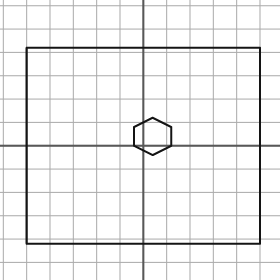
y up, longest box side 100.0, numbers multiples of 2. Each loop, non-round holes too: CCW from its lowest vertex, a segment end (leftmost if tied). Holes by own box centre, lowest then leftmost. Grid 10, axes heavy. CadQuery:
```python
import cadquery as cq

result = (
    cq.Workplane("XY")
    .moveTo(-50.0, -42.0)
    .lineTo(50.0, -42.0)
    .lineTo(50.0, 42.0)
    .lineTo(-50.0, 42.0)
    .close()
    .moveTo(4.0, -4.0)
    .lineTo(12.0, 0.0)
    .lineTo(12.0, 8.0)
    .lineTo(4.0, 12.0)
    .lineTo(-4.0, 8.0)
    .lineTo(-4.0, 0.0)
    .close()
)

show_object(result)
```